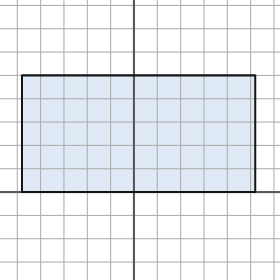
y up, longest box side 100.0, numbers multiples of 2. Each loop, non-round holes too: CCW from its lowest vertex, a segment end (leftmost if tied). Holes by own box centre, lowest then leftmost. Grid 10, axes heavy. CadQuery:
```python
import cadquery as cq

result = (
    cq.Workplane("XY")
    .moveTo(-48.0, 0.0)
    .lineTo(52.0, 0.0)
    .lineTo(52.0, 50.0)
    .lineTo(-48.0, 50.0)
    .close()
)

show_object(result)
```